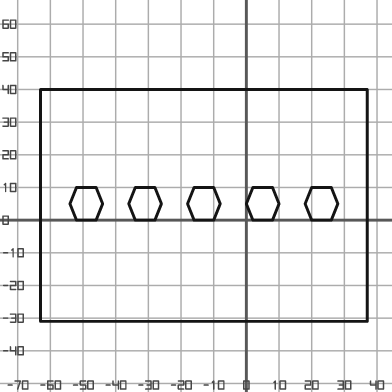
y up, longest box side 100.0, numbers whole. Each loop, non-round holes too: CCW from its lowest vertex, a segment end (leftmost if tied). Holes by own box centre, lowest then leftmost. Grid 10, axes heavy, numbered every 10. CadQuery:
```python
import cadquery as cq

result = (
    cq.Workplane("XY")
    .moveTo(-63.0, -31.0)
    .lineTo(37.0, -31.0)
    .lineTo(37.0, 40.0)
    .lineTo(-63.0, 40.0)
    .close()
    .moveTo(-52.0, 0.0)
    .lineTo(-46.0, 0.0)
    .lineTo(-44.0, 5.0)
    .lineTo(-46.0, 10.0)
    .lineTo(-52.0, 10.0)
    .lineTo(-54.0, 5.0)
    .close()
    .moveTo(-34.0, 0.0)
    .lineTo(-28.0, 0.0)
    .lineTo(-26.0, 5.0)
    .lineTo(-28.0, 10.0)
    .lineTo(-34.0, 10.0)
    .lineTo(-36.0, 5.0)
    .close()
    .moveTo(-16.0, 0.0)
    .lineTo(-10.0, 0.0)
    .lineTo(-8.0, 5.0)
    .lineTo(-10.0, 10.0)
    .lineTo(-16.0, 10.0)
    .lineTo(-18.0, 5.0)
    .close()
    .moveTo(2.0, 0.0)
    .lineTo(8.0, 0.0)
    .lineTo(10.0, 5.0)
    .lineTo(8.0, 10.0)
    .lineTo(2.0, 10.0)
    .lineTo(0.0, 5.0)
    .close()
    .moveTo(20.0, 0.0)
    .lineTo(26.0, 0.0)
    .lineTo(28.0, 5.0)
    .lineTo(26.0, 10.0)
    .lineTo(20.0, 10.0)
    .lineTo(18.0, 5.0)
    .close()
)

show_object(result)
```